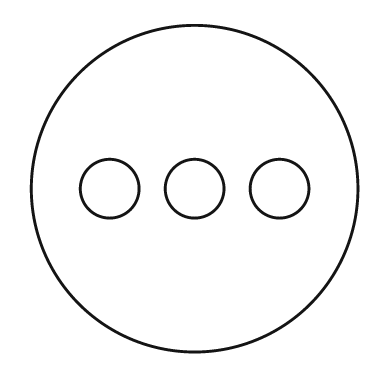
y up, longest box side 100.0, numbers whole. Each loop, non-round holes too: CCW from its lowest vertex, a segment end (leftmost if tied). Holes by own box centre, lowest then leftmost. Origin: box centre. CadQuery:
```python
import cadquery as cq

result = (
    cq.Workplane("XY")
    .moveTo(0.0, 0.0)
    .circle(50.0)
    .moveTo(-26.0, 0.0)
    .circle(9.0)
    .moveTo(0.0, 0.0)
    .circle(9.0)
    .moveTo(26.0, 0.0)
    .circle(9.0)
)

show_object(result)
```